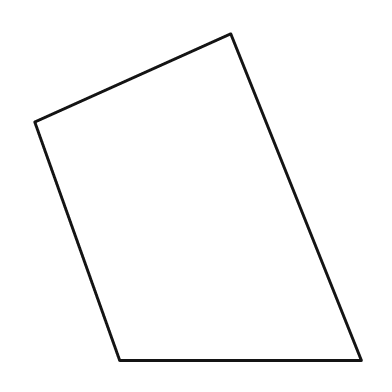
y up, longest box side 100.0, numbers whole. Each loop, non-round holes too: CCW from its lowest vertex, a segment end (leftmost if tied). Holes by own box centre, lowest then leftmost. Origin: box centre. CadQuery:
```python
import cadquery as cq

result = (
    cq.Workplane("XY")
    .moveTo(-24.0, -50.0)
    .lineTo(50.0, -50.0)
    .lineTo(10.0, 50.0)
    .lineTo(-50.0, 23.0)
    .close()
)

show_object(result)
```